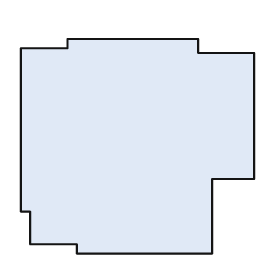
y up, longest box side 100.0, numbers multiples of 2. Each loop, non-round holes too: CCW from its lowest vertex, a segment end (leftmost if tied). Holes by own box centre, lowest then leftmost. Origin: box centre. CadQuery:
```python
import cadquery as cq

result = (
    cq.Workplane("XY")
    .moveTo(-26.0, -46.0)
    .lineTo(32.0, -46.0)
    .lineTo(32.0, -14.0)
    .lineTo(50.0, -14.0)
    .lineTo(50.0, 40.0)
    .lineTo(26.0, 40.0)
    .lineTo(26.0, 46.0)
    .lineTo(-30.0, 46.0)
    .lineTo(-30.0, 42.0)
    .lineTo(-50.0, 42.0)
    .lineTo(-50.0, -28.0)
    .lineTo(-46.0, -28.0)
    .lineTo(-46.0, -42.0)
    .lineTo(-26.0, -42.0)
    .close()
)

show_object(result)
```